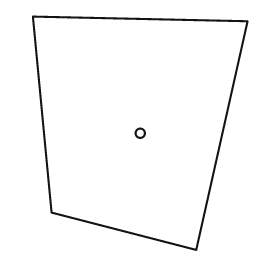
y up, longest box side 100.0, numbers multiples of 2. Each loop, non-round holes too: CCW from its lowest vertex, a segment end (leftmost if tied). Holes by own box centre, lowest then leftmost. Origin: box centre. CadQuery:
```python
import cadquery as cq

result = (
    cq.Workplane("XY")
    .moveTo(24.0, -50.0)
    .lineTo(46.0, 48.0)
    .lineTo(-46.0, 50.0)
    .lineTo(-38.0, -34.0)
    .close()
    .moveTo(0.0, 0.0)
    .circle(2.0)
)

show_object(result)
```